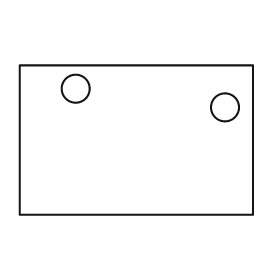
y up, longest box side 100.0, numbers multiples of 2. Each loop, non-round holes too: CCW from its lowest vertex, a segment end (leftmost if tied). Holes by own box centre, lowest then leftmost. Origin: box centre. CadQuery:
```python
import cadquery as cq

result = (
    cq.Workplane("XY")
    .moveTo(-50.0, -32.0)
    .lineTo(50.0, -32.0)
    .lineTo(50.0, 32.0)
    .lineTo(-50.0, 32.0)
    .close()
    .moveTo(38.0, 14.0)
    .circle(6.0)
    .moveTo(-26.0, 22.0)
    .circle(6.0)
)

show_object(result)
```